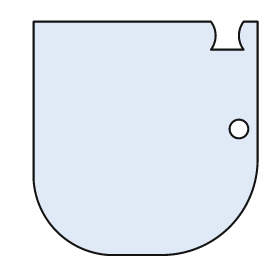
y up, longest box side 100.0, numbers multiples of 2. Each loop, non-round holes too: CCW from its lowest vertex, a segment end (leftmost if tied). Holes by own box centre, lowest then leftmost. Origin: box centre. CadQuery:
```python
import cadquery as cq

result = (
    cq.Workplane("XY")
    .moveTo(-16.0, -50.0)
    .lineTo(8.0, -50.0)
    .threePointArc((36.0, -38.0), (48.0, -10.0))
    .lineTo(48.0, 50.0)
    .lineTo(42.0, 50.0)
    .threePointArc((40.0, 44.0), (42.0, 38.0))
    .lineTo(28.0, 38.0)
    .threePointArc((30.0, 44.0), (28.0, 50.0))
    .lineTo(-48.0, 50.0)
    .lineTo(-48.0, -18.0)
    .threePointArc((-38.0, -40.0), (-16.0, -50.0))
    .close()
    .moveTo(40.0, 4.0)
    .circle(4.0)
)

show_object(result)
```